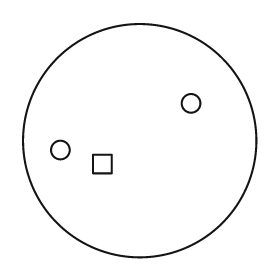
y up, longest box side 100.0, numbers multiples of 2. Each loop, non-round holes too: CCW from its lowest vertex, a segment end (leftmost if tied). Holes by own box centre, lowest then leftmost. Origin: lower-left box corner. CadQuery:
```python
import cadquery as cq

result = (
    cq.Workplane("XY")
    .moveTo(50.0, 50.0)
    .circle(50.0)
    .moveTo(30.0, 36.0)
    .lineTo(38.0, 36.0)
    .lineTo(38.0, 44.0)
    .lineTo(30.0, 44.0)
    .close()
    .moveTo(16.0, 46.0)
    .circle(4.0)
    .moveTo(72.0, 66.0)
    .circle(4.0)
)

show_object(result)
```